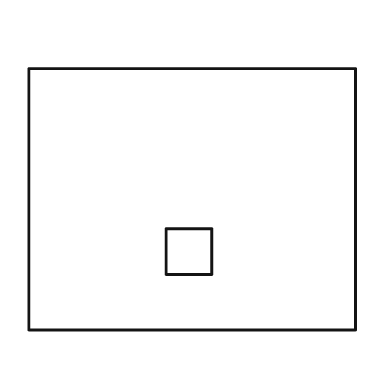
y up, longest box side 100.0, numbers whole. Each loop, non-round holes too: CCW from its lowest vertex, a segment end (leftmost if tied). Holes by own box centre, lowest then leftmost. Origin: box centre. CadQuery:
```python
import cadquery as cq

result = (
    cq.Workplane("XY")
    .moveTo(-50.0, -40.0)
    .lineTo(50.0, -40.0)
    .lineTo(50.0, 40.0)
    .lineTo(-50.0, 40.0)
    .close()
    .moveTo(-8.0, -23.0)
    .lineTo(6.0, -23.0)
    .lineTo(6.0, -9.0)
    .lineTo(-8.0, -9.0)
    .close()
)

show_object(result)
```